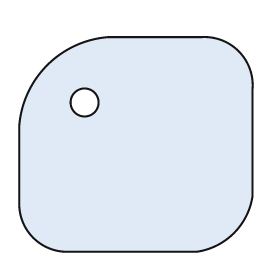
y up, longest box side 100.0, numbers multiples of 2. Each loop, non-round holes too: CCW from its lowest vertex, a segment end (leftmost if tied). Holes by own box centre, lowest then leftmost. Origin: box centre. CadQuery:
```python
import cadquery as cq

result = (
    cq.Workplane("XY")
    .moveTo(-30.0, -46.0)
    .lineTo(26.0, -46.0)
    .threePointArc((42.0, -38.0), (50.0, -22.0))
    .lineTo(50.0, 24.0)
    .threePointArc((44.0, 40.0), (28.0, 46.0))
    .lineTo(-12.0, 46.0)
    .threePointArc((-38.0, 34.0), (-50.0, 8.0))
    .lineTo(-50.0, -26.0)
    .threePointArc((-44.0, -40.0), (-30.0, -46.0))
    .close()
    .moveTo(-22.0, 18.0)
    .circle(6.0)
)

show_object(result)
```